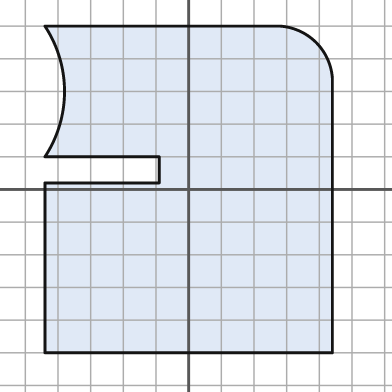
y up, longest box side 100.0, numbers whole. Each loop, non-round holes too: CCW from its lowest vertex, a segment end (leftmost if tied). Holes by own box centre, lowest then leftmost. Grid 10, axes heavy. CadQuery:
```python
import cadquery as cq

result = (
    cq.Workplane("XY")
    .moveTo(-44.0, -50.0)
    .lineTo(44.0, -50.0)
    .lineTo(44.0, 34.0)
    .threePointArc((39.0, 45.0), (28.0, 50.0))
    .lineTo(-44.0, 50.0)
    .threePointArc((-38.0, 30.0), (-44.0, 10.0))
    .lineTo(-9.0, 10.0)
    .lineTo(-9.0, 2.0)
    .lineTo(-44.0, 2.0)
    .close()
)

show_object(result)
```